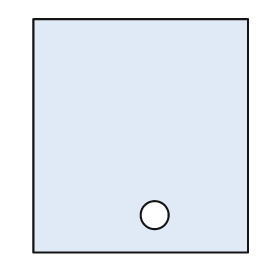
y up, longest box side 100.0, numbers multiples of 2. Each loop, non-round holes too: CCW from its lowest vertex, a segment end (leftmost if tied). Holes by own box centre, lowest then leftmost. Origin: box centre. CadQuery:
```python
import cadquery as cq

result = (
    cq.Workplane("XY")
    .moveTo(-46.0, -50.0)
    .lineTo(46.0, -50.0)
    .lineTo(46.0, 50.0)
    .lineTo(-46.0, 50.0)
    .close()
    .moveTo(6.0, -34.0)
    .circle(6.0)
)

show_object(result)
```